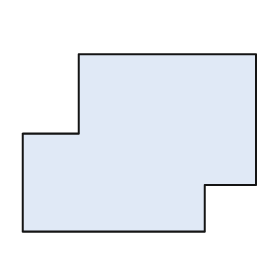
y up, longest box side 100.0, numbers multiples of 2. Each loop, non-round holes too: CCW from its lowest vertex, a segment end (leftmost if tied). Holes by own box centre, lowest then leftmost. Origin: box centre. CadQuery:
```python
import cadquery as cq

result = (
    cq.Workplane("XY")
    .moveTo(-50.0, -38.0)
    .lineTo(28.0, -38.0)
    .lineTo(28.0, -18.0)
    .lineTo(50.0, -18.0)
    .lineTo(50.0, 38.0)
    .lineTo(-26.0, 38.0)
    .lineTo(-26.0, 4.0)
    .lineTo(-50.0, 4.0)
    .close()
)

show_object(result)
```